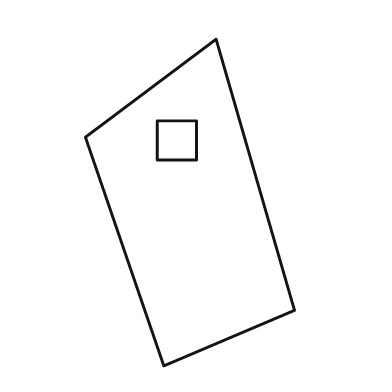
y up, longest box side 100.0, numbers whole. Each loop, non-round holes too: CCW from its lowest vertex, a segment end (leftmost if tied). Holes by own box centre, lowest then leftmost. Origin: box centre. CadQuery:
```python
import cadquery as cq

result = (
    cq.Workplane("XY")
    .moveTo(-8.0, -50.0)
    .lineTo(32.0, -33.0)
    .lineTo(8.0, 50.0)
    .lineTo(-32.0, 20.0)
    .close()
    .moveTo(-10.0, 13.0)
    .lineTo(2.0, 13.0)
    .lineTo(2.0, 25.0)
    .lineTo(-10.0, 25.0)
    .close()
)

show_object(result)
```